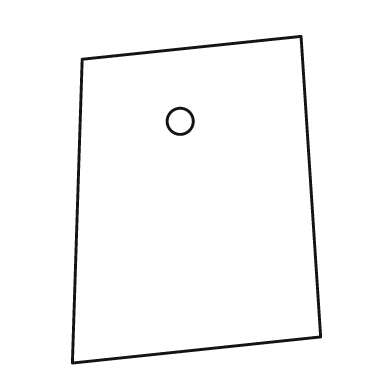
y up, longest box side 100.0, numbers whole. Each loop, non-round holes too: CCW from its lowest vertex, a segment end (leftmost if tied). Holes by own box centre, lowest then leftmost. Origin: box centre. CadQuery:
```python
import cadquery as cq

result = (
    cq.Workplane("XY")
    .moveTo(-38.0, -50.0)
    .lineTo(38.0, -42.0)
    .lineTo(32.0, 50.0)
    .lineTo(-35.0, 43.0)
    .close()
    .moveTo(-5.0, 24.0)
    .circle(4.0)
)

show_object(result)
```